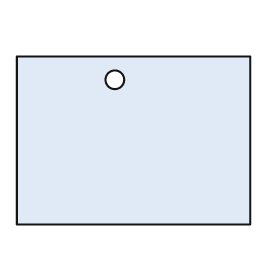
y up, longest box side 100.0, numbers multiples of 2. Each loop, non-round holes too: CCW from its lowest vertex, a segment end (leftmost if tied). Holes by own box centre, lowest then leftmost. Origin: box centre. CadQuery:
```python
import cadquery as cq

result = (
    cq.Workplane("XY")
    .moveTo(-50.0, -36.0)
    .lineTo(50.0, -36.0)
    .lineTo(50.0, 36.0)
    .lineTo(-50.0, 36.0)
    .close()
    .moveTo(-8.0, 26.0)
    .circle(4.0)
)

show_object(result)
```